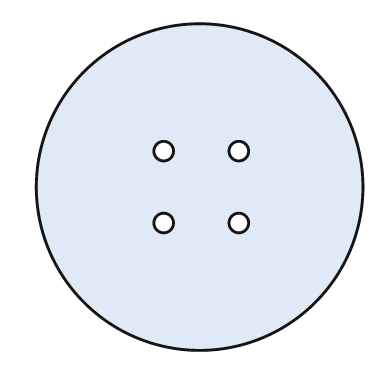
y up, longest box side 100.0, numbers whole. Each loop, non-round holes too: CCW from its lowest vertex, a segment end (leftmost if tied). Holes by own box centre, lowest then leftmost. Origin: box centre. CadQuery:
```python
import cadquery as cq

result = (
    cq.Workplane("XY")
    .moveTo(0.0, 0.0)
    .circle(50.0)
    .moveTo(-11.0, -11.0)
    .circle(3.0)
    .moveTo(12.0, -11.0)
    .circle(3.0)
    .moveTo(-11.0, 11.0)
    .circle(3.0)
    .moveTo(12.0, 11.0)
    .circle(3.0)
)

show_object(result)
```